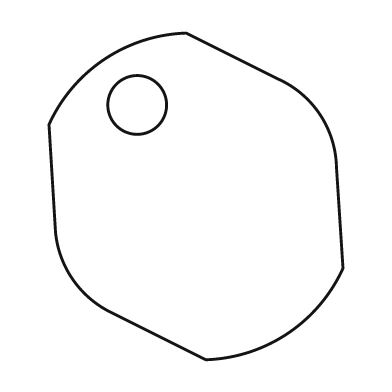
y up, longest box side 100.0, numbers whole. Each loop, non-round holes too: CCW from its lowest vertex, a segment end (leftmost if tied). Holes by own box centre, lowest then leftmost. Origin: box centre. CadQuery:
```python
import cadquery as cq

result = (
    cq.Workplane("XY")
    .moveTo(3.0, -50.0)
    .threePointArc((28.0, -42.0), (45.0, -22.0))
    .lineTo(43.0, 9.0)
    .threePointArc((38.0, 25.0), (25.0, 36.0))
    .lineTo(-3.0, 50.0)
    .threePointArc((-28.0, 42.0), (-45.0, 22.0))
    .lineTo(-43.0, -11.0)
    .threePointArc((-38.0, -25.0), (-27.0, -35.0))
    .close()
    .moveTo(-18.0, 28.0)
    .circle(9.0)
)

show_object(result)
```